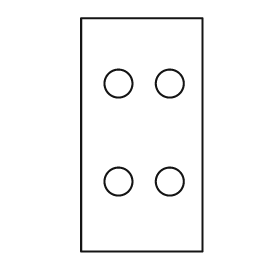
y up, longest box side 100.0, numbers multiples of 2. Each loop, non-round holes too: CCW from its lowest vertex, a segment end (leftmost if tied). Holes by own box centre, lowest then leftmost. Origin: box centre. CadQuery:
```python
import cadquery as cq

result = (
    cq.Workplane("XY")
    .moveTo(-26.0, -50.0)
    .lineTo(26.0, -50.0)
    .lineTo(26.0, 50.0)
    .lineTo(-26.0, 50.0)
    .close()
    .moveTo(-10.0, -20.0)
    .circle(6.0)
    .moveTo(12.0, -20.0)
    .circle(6.0)
    .moveTo(-10.0, 22.0)
    .circle(6.0)
    .moveTo(12.0, 22.0)
    .circle(6.0)
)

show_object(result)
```